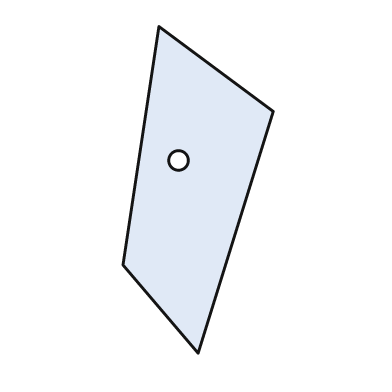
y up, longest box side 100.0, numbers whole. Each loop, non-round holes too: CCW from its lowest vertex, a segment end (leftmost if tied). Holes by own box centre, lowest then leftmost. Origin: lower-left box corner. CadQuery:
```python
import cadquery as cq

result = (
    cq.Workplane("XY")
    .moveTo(23.0, 0.0)
    .lineTo(46.0, 74.0)
    .lineTo(11.0, 100.0)
    .lineTo(0.0, 27.0)
    .close()
    .moveTo(17.0, 59.0)
    .circle(3.0)
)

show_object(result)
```